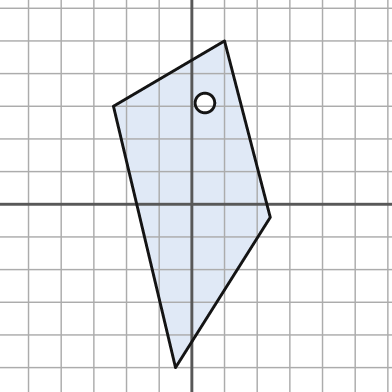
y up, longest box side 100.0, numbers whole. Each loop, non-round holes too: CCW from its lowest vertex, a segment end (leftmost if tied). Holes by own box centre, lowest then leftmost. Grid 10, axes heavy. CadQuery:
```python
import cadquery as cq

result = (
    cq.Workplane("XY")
    .moveTo(-5.0, -50.0)
    .lineTo(24.0, -4.0)
    .lineTo(10.0, 50.0)
    .lineTo(-24.0, 30.0)
    .close()
    .moveTo(4.0, 31.0)
    .circle(3.0)
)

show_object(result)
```